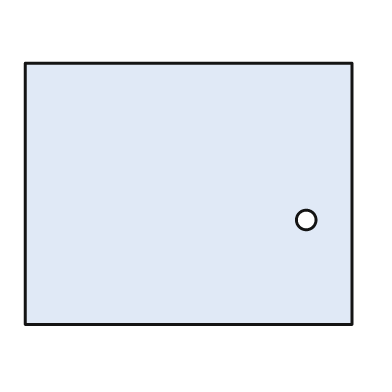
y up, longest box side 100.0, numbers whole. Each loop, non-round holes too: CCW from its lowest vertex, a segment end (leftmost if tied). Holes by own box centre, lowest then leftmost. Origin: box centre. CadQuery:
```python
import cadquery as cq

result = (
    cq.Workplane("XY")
    .moveTo(-50.0, -40.0)
    .lineTo(50.0, -40.0)
    .lineTo(50.0, 40.0)
    .lineTo(-50.0, 40.0)
    .close()
    .moveTo(36.0, -8.0)
    .circle(3.0)
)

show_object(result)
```